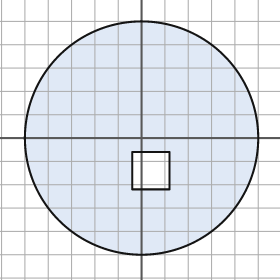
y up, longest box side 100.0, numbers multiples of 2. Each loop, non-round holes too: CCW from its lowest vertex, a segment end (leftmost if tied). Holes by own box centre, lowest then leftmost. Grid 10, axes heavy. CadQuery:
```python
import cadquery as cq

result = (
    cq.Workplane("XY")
    .moveTo(0.0, 0.0)
    .circle(50.0)
    .moveTo(-4.0, -22.0)
    .lineTo(12.0, -22.0)
    .lineTo(12.0, -6.0)
    .lineTo(-4.0, -6.0)
    .close()
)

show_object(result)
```